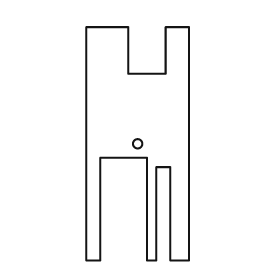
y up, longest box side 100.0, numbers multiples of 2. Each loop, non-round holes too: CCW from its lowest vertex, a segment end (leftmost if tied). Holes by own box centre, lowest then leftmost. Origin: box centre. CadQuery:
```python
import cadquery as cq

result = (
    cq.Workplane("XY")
    .moveTo(-22.0, -50.0)
    .lineTo(-16.0, -50.0)
    .lineTo(-16.0, -6.0)
    .lineTo(4.0, -6.0)
    .lineTo(4.0, -50.0)
    .lineTo(8.0, -50.0)
    .lineTo(8.0, -10.0)
    .lineTo(14.0, -10.0)
    .lineTo(14.0, -50.0)
    .lineTo(22.0, -50.0)
    .lineTo(22.0, 50.0)
    .lineTo(12.0, 50.0)
    .lineTo(12.0, 30.0)
    .lineTo(-4.0, 30.0)
    .lineTo(-4.0, 50.0)
    .lineTo(-22.0, 50.0)
    .close()
    .moveTo(0.0, 0.0)
    .circle(2.0)
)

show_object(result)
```